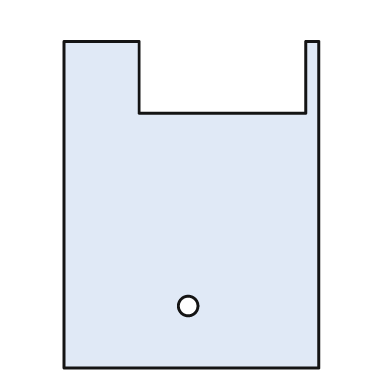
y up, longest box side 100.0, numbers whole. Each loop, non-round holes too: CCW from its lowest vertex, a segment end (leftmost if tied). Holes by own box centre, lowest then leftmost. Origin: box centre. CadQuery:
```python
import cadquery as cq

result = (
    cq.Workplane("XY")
    .moveTo(-39.0, -50.0)
    .lineTo(39.0, -50.0)
    .lineTo(39.0, 50.0)
    .lineTo(35.0, 50.0)
    .lineTo(35.0, 28.0)
    .lineTo(-16.0, 28.0)
    .lineTo(-16.0, 50.0)
    .lineTo(-39.0, 50.0)
    .close()
    .moveTo(-1.0, -31.0)
    .circle(3.0)
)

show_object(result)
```